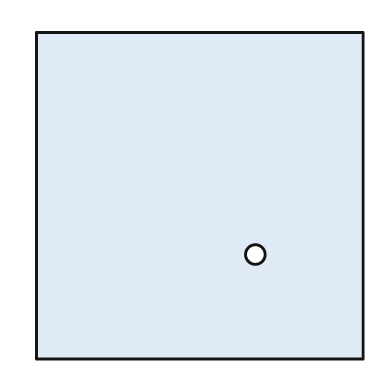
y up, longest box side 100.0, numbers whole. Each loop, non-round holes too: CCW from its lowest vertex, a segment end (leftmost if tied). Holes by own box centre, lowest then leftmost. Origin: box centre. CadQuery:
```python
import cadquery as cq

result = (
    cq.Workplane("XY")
    .moveTo(-50.0, -50.0)
    .lineTo(50.0, -50.0)
    .lineTo(50.0, 50.0)
    .lineTo(-50.0, 50.0)
    .close()
    .moveTo(17.0, -18.0)
    .circle(3.0)
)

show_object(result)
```